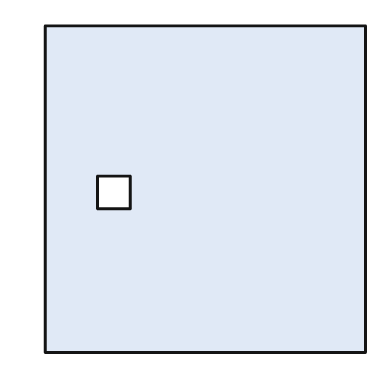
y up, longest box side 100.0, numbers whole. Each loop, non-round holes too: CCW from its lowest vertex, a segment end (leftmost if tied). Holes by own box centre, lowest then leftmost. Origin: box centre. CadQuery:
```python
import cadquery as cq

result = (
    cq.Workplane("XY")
    .moveTo(-49.0, -50.0)
    .lineTo(49.0, -50.0)
    .lineTo(49.0, 50.0)
    .lineTo(-49.0, 50.0)
    .close()
    .moveTo(-33.0, -6.0)
    .lineTo(-23.0, -6.0)
    .lineTo(-23.0, 4.0)
    .lineTo(-33.0, 4.0)
    .close()
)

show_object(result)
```